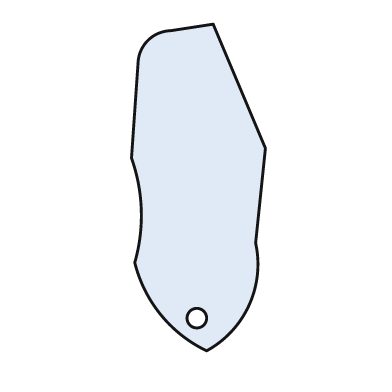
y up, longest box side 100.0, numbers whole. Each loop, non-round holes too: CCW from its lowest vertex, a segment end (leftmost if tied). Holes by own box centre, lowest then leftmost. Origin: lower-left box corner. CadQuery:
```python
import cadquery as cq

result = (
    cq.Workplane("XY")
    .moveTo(23.0, 0.0)
    .threePointArc((36.0, 14.0), (38.0, 33.0))
    .lineTo(41.0, 62.0)
    .lineTo(25.0, 100.0)
    .lineTo(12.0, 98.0)
    .threePointArc((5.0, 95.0), (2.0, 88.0))
    .lineTo(0.0, 59.0)
    .threePointArc((3.0, 43.0), (1.0, 27.0))
    .threePointArc((9.0, 11.0), (23.0, 0.0))
    .close()
    .moveTo(20.0, 10.0)
    .circle(3.0)
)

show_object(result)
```